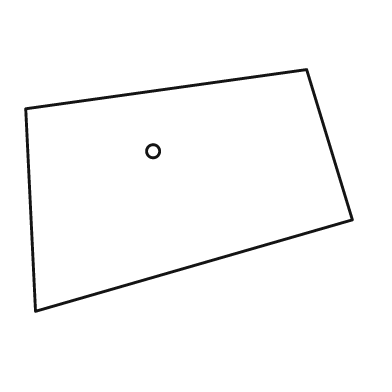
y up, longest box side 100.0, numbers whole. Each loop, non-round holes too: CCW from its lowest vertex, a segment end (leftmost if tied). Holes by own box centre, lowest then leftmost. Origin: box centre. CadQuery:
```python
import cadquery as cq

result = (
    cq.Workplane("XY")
    .moveTo(-47.0, -37.0)
    .lineTo(50.0, -9.0)
    .lineTo(36.0, 37.0)
    .lineTo(-50.0, 25.0)
    .close()
    .moveTo(-11.0, 12.0)
    .circle(2.0)
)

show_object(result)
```